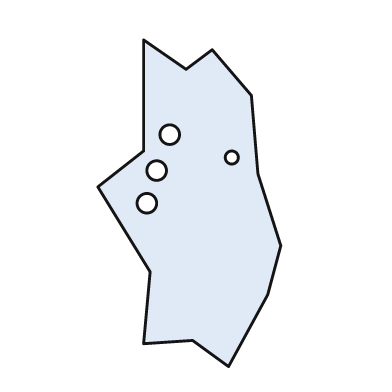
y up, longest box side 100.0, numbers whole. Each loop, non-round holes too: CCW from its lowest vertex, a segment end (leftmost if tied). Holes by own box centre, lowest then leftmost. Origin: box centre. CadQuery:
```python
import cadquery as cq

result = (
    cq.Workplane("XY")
    .moveTo(12.0, -50.0)
    .lineTo(24.0, -28.0)
    .lineTo(28.0, -13.0)
    .lineTo(21.0, 9.0)
    .lineTo(19.0, 33.0)
    .lineTo(7.0, 47.0)
    .lineTo(-1.0, 41.0)
    .lineTo(-14.0, 50.0)
    .lineTo(-14.0, 16.0)
    .lineTo(-28.0, 5.0)
    .lineTo(-12.0, -21.0)
    .lineTo(-14.0, -43.0)
    .lineTo(1.0, -42.0)
    .close()
    .moveTo(-13.0, 0.0)
    .circle(3.0)
    .moveTo(-10.0, 10.0)
    .circle(3.0)
    .moveTo(13.0, 14.0)
    .circle(2.0)
    .moveTo(-6.0, 21.0)
    .circle(3.0)
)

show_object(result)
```